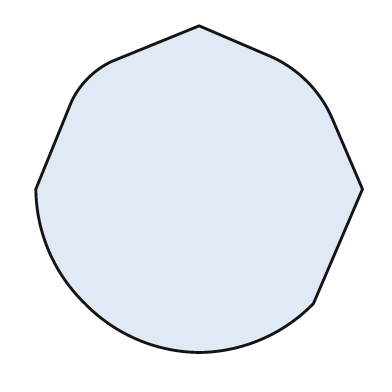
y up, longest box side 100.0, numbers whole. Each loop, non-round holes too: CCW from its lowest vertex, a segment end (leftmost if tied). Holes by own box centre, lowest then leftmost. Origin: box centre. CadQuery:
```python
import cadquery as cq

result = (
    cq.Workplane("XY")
    .moveTo(0.0, -50.0)
    .threePointArc((19.0, -46.0), (35.0, -35.0))
    .lineTo(50.0, 0.0)
    .lineTo(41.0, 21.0)
    .threePointArc((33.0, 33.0), (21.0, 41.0))
    .lineTo(0.0, 50.0)
    .lineTo(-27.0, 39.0)
    .threePointArc((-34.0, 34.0), (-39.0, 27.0))
    .lineTo(-50.0, 0.0)
    .threePointArc((-46.0, -19.0), (-35.0, -35.0))
    .threePointArc((-19.0, -46.0), (0.0, -50.0))
    .close()
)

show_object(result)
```